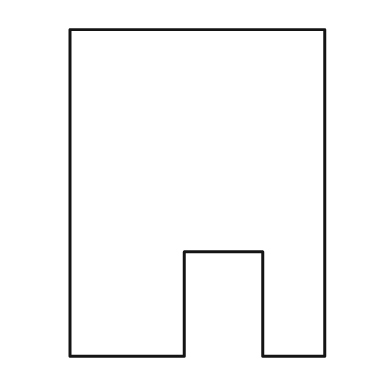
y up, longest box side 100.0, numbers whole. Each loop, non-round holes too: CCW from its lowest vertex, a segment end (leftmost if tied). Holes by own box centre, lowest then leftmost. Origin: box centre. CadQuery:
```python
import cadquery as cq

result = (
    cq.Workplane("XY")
    .moveTo(-39.0, -50.0)
    .lineTo(-4.0, -50.0)
    .lineTo(-4.0, -18.0)
    .lineTo(20.0, -18.0)
    .lineTo(20.0, -50.0)
    .lineTo(39.0, -50.0)
    .lineTo(39.0, 50.0)
    .lineTo(-39.0, 50.0)
    .close()
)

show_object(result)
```